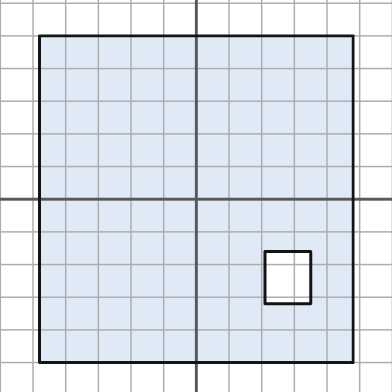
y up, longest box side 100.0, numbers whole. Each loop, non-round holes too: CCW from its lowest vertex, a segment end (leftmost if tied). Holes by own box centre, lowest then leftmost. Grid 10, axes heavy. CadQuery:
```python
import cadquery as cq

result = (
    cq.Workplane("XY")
    .moveTo(-48.0, -50.0)
    .lineTo(48.0, -50.0)
    .lineTo(48.0, 50.0)
    .lineTo(-48.0, 50.0)
    .close()
    .moveTo(21.0, -32.0)
    .lineTo(35.0, -32.0)
    .lineTo(35.0, -16.0)
    .lineTo(21.0, -16.0)
    .close()
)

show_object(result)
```